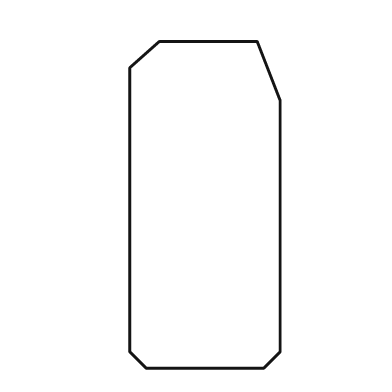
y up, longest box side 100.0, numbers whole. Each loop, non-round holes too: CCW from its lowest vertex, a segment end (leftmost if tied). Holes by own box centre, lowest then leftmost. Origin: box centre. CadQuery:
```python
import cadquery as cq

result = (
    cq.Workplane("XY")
    .moveTo(-18.0, -50.0)
    .lineTo(18.0, -50.0)
    .lineTo(23.0, -45.0)
    .lineTo(23.0, 32.0)
    .lineTo(16.0, 50.0)
    .lineTo(-14.0, 50.0)
    .lineTo(-23.0, 42.0)
    .lineTo(-23.0, -45.0)
    .close()
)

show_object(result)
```